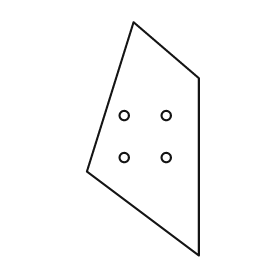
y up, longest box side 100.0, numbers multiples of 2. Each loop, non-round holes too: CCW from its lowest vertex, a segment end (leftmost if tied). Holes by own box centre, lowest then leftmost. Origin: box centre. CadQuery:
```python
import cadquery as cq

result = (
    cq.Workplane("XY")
    .moveTo(24.0, -50.0)
    .lineTo(24.0, 26.0)
    .lineTo(-4.0, 50.0)
    .lineTo(-24.0, -14.0)
    .close()
    .moveTo(-8.0, -8.0)
    .circle(2.0)
    .moveTo(10.0, -8.0)
    .circle(2.0)
    .moveTo(-8.0, 10.0)
    .circle(2.0)
    .moveTo(10.0, 10.0)
    .circle(2.0)
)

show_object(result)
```